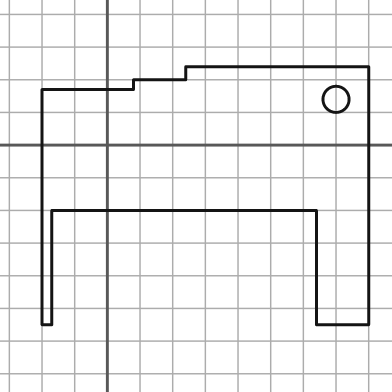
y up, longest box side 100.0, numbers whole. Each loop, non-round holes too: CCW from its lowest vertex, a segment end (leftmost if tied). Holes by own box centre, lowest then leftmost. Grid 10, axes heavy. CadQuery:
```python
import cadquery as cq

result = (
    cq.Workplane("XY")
    .moveTo(-20.0, -55.0)
    .lineTo(-17.0, -55.0)
    .lineTo(-17.0, -20.0)
    .lineTo(64.0, -20.0)
    .lineTo(64.0, -55.0)
    .lineTo(80.0, -55.0)
    .lineTo(80.0, 24.0)
    .lineTo(24.0, 24.0)
    .lineTo(24.0, 20.0)
    .lineTo(8.0, 20.0)
    .lineTo(8.0, 17.0)
    .lineTo(-20.0, 17.0)
    .close()
    .moveTo(70.0, 14.0)
    .circle(4.0)
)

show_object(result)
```